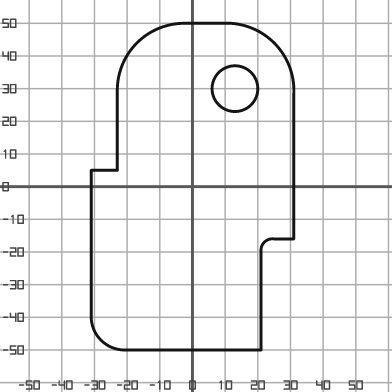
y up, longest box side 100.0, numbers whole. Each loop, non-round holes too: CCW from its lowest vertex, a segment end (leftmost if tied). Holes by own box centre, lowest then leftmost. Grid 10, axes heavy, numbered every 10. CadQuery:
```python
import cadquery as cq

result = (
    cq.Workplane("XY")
    .moveTo(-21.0, -50.0)
    .lineTo(21.0, -50.0)
    .lineTo(21.0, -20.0)
    .threePointArc((22.0, -17.0), (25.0, -16.0))
    .lineTo(31.0, -16.0)
    .lineTo(31.0, 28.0)
    .threePointArc((25.0, 44.0), (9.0, 50.0))
    .lineTo(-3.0, 50.0)
    .threePointArc((-17.0, 44.0), (-23.0, 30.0))
    .lineTo(-23.0, 5.0)
    .lineTo(-31.0, 5.0)
    .lineTo(-31.0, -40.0)
    .threePointArc((-28.0, -47.0), (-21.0, -50.0))
    .close()
    .moveTo(13.0, 30.0)
    .circle(7.0)
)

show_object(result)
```